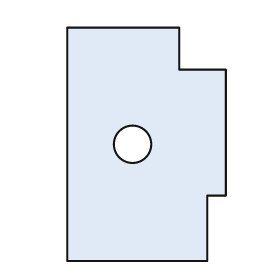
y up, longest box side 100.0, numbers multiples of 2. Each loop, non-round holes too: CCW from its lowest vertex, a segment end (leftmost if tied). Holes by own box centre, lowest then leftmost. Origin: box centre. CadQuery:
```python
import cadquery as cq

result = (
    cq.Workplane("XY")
    .moveTo(-34.0, -50.0)
    .lineTo(26.0, -50.0)
    .lineTo(26.0, -22.0)
    .lineTo(34.0, -22.0)
    .lineTo(34.0, 32.0)
    .lineTo(14.0, 32.0)
    .lineTo(14.0, 50.0)
    .lineTo(-34.0, 50.0)
    .close()
    .moveTo(-6.0, 0.0)
    .circle(8.0)
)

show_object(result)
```